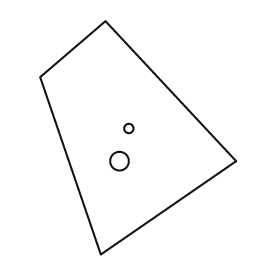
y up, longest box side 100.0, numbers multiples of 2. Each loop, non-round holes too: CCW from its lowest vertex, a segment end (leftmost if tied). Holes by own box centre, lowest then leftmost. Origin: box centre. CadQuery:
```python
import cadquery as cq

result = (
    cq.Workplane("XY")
    .moveTo(-16.0, -50.0)
    .lineTo(42.0, -10.0)
    .lineTo(-14.0, 50.0)
    .lineTo(-42.0, 26.0)
    .close()
    .moveTo(-8.0, -10.0)
    .circle(4.0)
    .moveTo(-4.0, 4.0)
    .circle(2.0)
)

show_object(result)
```